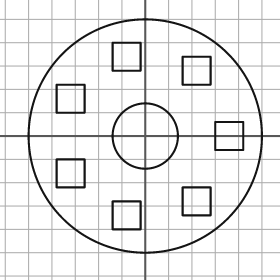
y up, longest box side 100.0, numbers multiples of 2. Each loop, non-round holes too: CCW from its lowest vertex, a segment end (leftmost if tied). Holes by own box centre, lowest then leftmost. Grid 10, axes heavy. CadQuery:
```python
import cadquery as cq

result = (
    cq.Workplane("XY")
    .moveTo(0.0, 0.0)
    .circle(50.0)
    .moveTo(-14.0, -40.0)
    .lineTo(-2.0, -40.0)
    .lineTo(-2.0, -28.0)
    .lineTo(-14.0, -28.0)
    .close()
    .moveTo(16.0, -34.0)
    .lineTo(28.0, -34.0)
    .lineTo(28.0, -22.0)
    .lineTo(16.0, -22.0)
    .close()
    .moveTo(-38.0, -22.0)
    .lineTo(-26.0, -22.0)
    .lineTo(-26.0, -10.0)
    .lineTo(-38.0, -10.0)
    .close()
    .moveTo(0.0, 0.0)
    .circle(14.0)
    .moveTo(30.0, -6.0)
    .lineTo(42.0, -6.0)
    .lineTo(42.0, 6.0)
    .lineTo(30.0, 6.0)
    .close()
    .moveTo(-38.0, 10.0)
    .lineTo(-26.0, 10.0)
    .lineTo(-26.0, 22.0)
    .lineTo(-38.0, 22.0)
    .close()
    .moveTo(16.0, 22.0)
    .lineTo(28.0, 22.0)
    .lineTo(28.0, 34.0)
    .lineTo(16.0, 34.0)
    .close()
    .moveTo(-14.0, 28.0)
    .lineTo(-2.0, 28.0)
    .lineTo(-2.0, 40.0)
    .lineTo(-14.0, 40.0)
    .close()
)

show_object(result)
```